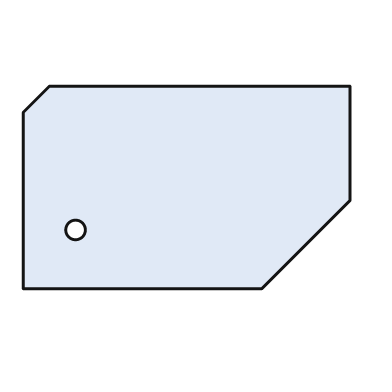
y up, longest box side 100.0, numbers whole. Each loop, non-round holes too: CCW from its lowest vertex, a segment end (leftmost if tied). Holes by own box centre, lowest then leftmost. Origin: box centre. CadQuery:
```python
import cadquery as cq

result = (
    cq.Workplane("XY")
    .moveTo(-50.0, -31.0)
    .lineTo(23.0, -31.0)
    .lineTo(50.0, -4.0)
    .lineTo(50.0, 31.0)
    .lineTo(-42.0, 31.0)
    .lineTo(-50.0, 23.0)
    .close()
    .moveTo(-34.0, -13.0)
    .circle(3.0)
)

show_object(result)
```